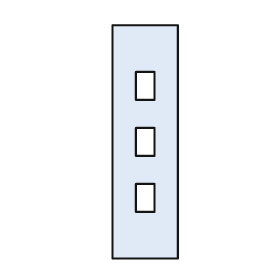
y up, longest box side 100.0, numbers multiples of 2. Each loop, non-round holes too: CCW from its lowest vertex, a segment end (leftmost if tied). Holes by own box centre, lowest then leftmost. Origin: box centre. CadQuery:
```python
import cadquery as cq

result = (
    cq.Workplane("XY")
    .moveTo(-14.0, -50.0)
    .lineTo(14.0, -50.0)
    .lineTo(14.0, 50.0)
    .lineTo(-14.0, 50.0)
    .close()
    .moveTo(-4.0, -30.0)
    .lineTo(4.0, -30.0)
    .lineTo(4.0, -18.0)
    .lineTo(-4.0, -18.0)
    .close()
    .moveTo(-4.0, -6.0)
    .lineTo(4.0, -6.0)
    .lineTo(4.0, 6.0)
    .lineTo(-4.0, 6.0)
    .close()
    .moveTo(-4.0, 18.0)
    .lineTo(4.0, 18.0)
    .lineTo(4.0, 30.0)
    .lineTo(-4.0, 30.0)
    .close()
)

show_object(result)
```